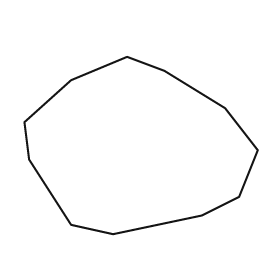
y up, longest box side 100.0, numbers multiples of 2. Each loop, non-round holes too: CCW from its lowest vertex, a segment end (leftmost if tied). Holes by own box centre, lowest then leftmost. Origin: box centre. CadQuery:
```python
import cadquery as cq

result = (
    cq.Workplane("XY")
    .moveTo(-12.0, -38.0)
    .lineTo(26.0, -30.0)
    .lineTo(42.0, -22.0)
    .lineTo(50.0, -2.0)
    .lineTo(36.0, 16.0)
    .lineTo(10.0, 32.0)
    .lineTo(-6.0, 38.0)
    .lineTo(-30.0, 28.0)
    .lineTo(-50.0, 10.0)
    .lineTo(-48.0, -6.0)
    .lineTo(-30.0, -34.0)
    .close()
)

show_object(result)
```